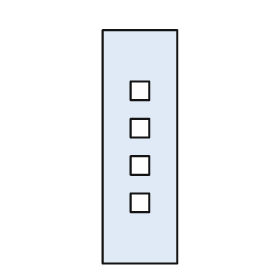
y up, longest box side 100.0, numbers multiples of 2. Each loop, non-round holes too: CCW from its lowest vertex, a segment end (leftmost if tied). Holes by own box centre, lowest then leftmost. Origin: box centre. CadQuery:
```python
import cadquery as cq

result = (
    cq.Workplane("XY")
    .moveTo(-16.0, -50.0)
    .lineTo(16.0, -50.0)
    .lineTo(16.0, 50.0)
    .lineTo(-16.0, 50.0)
    .close()
    .moveTo(-4.0, -28.0)
    .lineTo(4.0, -28.0)
    .lineTo(4.0, -20.0)
    .lineTo(-4.0, -20.0)
    .close()
    .moveTo(-4.0, -12.0)
    .lineTo(4.0, -12.0)
    .lineTo(4.0, -4.0)
    .lineTo(-4.0, -4.0)
    .close()
    .moveTo(-4.0, 4.0)
    .lineTo(4.0, 4.0)
    .lineTo(4.0, 12.0)
    .lineTo(-4.0, 12.0)
    .close()
    .moveTo(-4.0, 20.0)
    .lineTo(4.0, 20.0)
    .lineTo(4.0, 28.0)
    .lineTo(-4.0, 28.0)
    .close()
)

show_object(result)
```